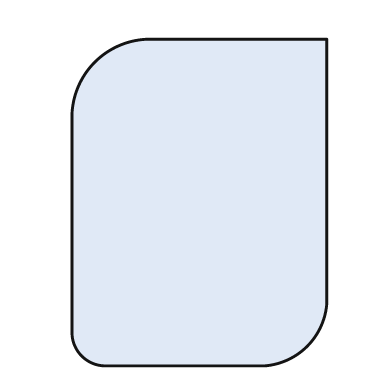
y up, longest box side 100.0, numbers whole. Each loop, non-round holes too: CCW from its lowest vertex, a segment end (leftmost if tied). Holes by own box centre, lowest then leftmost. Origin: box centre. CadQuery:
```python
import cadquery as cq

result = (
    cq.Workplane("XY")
    .moveTo(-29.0, -50.0)
    .lineTo(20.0, -50.0)
    .threePointArc((33.0, -44.0), (39.0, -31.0))
    .lineTo(39.0, 50.0)
    .lineTo(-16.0, 50.0)
    .threePointArc((-32.0, 43.0), (-39.0, 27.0))
    .lineTo(-39.0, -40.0)
    .threePointArc((-36.0, -47.0), (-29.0, -50.0))
    .close()
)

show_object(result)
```